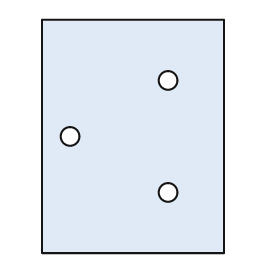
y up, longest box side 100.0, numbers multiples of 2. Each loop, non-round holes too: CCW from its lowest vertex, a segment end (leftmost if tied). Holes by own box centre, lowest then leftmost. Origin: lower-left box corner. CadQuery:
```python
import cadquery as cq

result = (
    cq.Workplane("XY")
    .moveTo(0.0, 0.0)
    .lineTo(78.0, 0.0)
    .lineTo(78.0, 100.0)
    .lineTo(0.0, 100.0)
    .close()
    .moveTo(54.0, 26.0)
    .circle(4.0)
    .moveTo(12.0, 50.0)
    .circle(4.0)
    .moveTo(54.0, 74.0)
    .circle(4.0)
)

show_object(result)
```